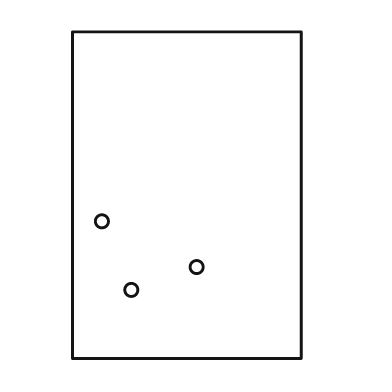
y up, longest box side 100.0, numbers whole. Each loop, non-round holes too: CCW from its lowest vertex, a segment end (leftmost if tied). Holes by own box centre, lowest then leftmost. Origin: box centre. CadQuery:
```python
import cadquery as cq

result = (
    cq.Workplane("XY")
    .moveTo(-35.0, -50.0)
    .lineTo(35.0, -50.0)
    .lineTo(35.0, 50.0)
    .lineTo(-35.0, 50.0)
    .close()
    .moveTo(-17.0, -29.0)
    .circle(2.0)
    .moveTo(3.0, -22.0)
    .circle(2.0)
    .moveTo(-26.0, -8.0)
    .circle(2.0)
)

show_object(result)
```